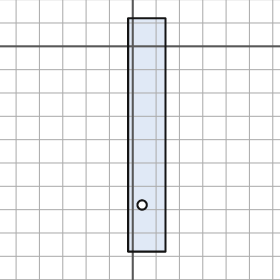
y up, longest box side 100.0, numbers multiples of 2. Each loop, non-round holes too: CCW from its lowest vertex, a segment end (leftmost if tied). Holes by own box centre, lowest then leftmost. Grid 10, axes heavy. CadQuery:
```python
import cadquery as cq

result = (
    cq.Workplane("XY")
    .moveTo(-2.0, -88.0)
    .lineTo(14.0, -88.0)
    .lineTo(14.0, 12.0)
    .lineTo(-2.0, 12.0)
    .close()
    .moveTo(4.0, -68.0)
    .circle(2.0)
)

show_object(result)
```